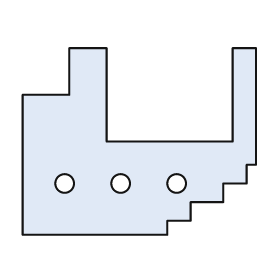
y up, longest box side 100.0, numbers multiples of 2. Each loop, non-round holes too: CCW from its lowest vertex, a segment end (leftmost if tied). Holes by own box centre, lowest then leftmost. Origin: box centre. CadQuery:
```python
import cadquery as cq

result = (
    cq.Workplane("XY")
    .moveTo(-50.0, -40.0)
    .lineTo(12.0, -40.0)
    .lineTo(12.0, -34.0)
    .lineTo(22.0, -34.0)
    .lineTo(22.0, -26.0)
    .lineTo(36.0, -26.0)
    .lineTo(36.0, -18.0)
    .lineTo(46.0, -18.0)
    .lineTo(46.0, -10.0)
    .lineTo(50.0, -10.0)
    .lineTo(50.0, 40.0)
    .lineTo(40.0, 40.0)
    .lineTo(40.0, 0.0)
    .lineTo(-14.0, 0.0)
    .lineTo(-14.0, 40.0)
    .lineTo(-30.0, 40.0)
    .lineTo(-30.0, 20.0)
    .lineTo(-50.0, 20.0)
    .close()
    .moveTo(-32.0, -18.0)
    .circle(4.0)
    .moveTo(-8.0, -18.0)
    .circle(4.0)
    .moveTo(16.0, -18.0)
    .circle(4.0)
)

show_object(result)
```